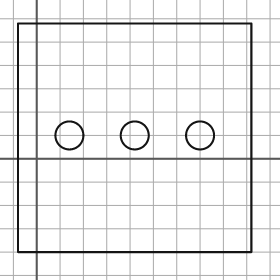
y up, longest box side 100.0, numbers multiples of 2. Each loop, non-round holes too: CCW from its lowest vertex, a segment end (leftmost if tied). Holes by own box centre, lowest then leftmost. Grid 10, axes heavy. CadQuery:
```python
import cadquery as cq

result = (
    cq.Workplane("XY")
    .moveTo(-8.0, -40.0)
    .lineTo(92.0, -40.0)
    .lineTo(92.0, 58.0)
    .lineTo(-8.0, 58.0)
    .close()
    .moveTo(14.0, 10.0)
    .circle(6.0)
    .moveTo(42.0, 10.0)
    .circle(6.0)
    .moveTo(70.0, 10.0)
    .circle(6.0)
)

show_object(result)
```